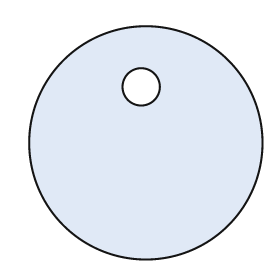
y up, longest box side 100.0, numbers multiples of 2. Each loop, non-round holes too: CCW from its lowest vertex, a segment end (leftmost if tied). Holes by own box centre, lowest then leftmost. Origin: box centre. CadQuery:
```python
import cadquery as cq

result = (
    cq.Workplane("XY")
    .moveTo(0.0, 0.0)
    .circle(50.0)
    .moveTo(-2.0, 24.0)
    .circle(8.0)
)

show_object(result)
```